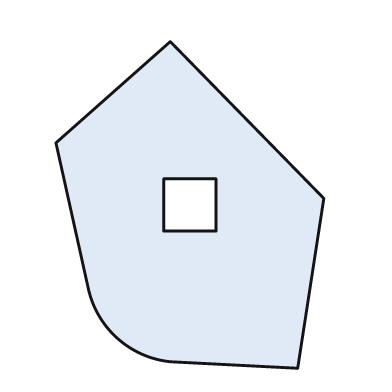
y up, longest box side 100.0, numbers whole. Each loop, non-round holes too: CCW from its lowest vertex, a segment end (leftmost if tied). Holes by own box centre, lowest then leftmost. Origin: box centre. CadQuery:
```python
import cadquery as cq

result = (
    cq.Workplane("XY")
    .moveTo(33.0, -50.0)
    .lineTo(41.0, 2.0)
    .lineTo(-6.0, 50.0)
    .lineTo(-41.0, 19.0)
    .lineTo(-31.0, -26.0)
    .threePointArc((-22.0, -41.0), (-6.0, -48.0))
    .close()
    .moveTo(-8.0, -8.0)
    .lineTo(8.0, -8.0)
    .lineTo(8.0, 8.0)
    .lineTo(-8.0, 8.0)
    .close()
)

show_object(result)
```